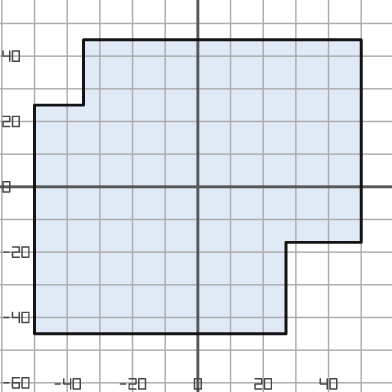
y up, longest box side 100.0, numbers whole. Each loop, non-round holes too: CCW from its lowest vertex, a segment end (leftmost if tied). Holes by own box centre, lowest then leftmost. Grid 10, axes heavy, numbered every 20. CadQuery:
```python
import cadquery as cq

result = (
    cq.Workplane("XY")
    .moveTo(-50.0, -45.0)
    .lineTo(27.0, -45.0)
    .lineTo(27.0, -17.0)
    .lineTo(50.0, -17.0)
    .lineTo(50.0, 45.0)
    .lineTo(-35.0, 45.0)
    .lineTo(-35.0, 25.0)
    .lineTo(-50.0, 25.0)
    .close()
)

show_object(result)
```